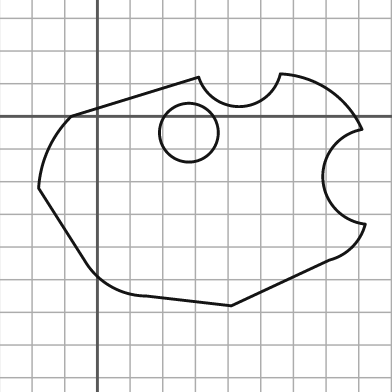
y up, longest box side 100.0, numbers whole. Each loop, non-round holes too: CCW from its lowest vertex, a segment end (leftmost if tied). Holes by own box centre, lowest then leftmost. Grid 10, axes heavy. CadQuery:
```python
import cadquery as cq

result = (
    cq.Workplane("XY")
    .moveTo(41.0, -58.0)
    .lineTo(71.0, -44.0)
    .threePointArc((78.0, -40.0), (82.0, -33.0))
    .threePointArc((69.0, -19.0), (81.0, -4.0))
    .threePointArc((71.0, 8.0), (56.0, 13.0))
    .threePointArc((44.0, 3.0), (31.0, 12.0))
    .lineTo(-8.0, 0.0)
    .threePointArc((-15.0, -10.0), (-18.0, -22.0))
    .lineTo(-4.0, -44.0)
    .threePointArc((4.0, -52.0), (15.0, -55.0))
    .close()
    .moveTo(28.0, -5.0)
    .circle(9.0)
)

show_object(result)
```